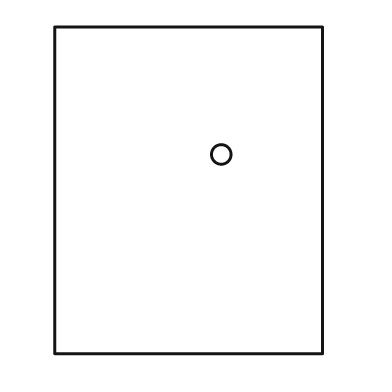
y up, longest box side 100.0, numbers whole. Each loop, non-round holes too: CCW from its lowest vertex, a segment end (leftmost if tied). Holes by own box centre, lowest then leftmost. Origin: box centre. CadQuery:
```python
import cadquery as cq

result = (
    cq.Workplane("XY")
    .moveTo(-41.0, -50.0)
    .lineTo(41.0, -50.0)
    .lineTo(41.0, 50.0)
    .lineTo(-41.0, 50.0)
    .close()
    .moveTo(10.0, 11.0)
    .circle(3.0)
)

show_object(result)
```